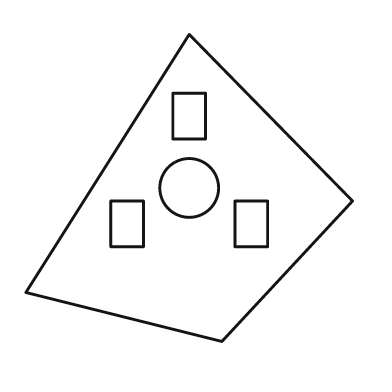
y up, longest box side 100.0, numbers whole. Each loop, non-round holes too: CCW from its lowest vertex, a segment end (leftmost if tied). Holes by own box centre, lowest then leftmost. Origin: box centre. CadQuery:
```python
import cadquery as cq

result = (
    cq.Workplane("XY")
    .moveTo(10.0, -47.0)
    .lineTo(50.0, -4.0)
    .lineTo(0.0, 47.0)
    .lineTo(-50.0, -32.0)
    .close()
    .moveTo(-24.0, -18.0)
    .lineTo(-14.0, -18.0)
    .lineTo(-14.0, -4.0)
    .lineTo(-24.0, -4.0)
    .close()
    .moveTo(14.0, -18.0)
    .lineTo(24.0, -18.0)
    .lineTo(24.0, -4.0)
    .lineTo(14.0, -4.0)
    .close()
    .moveTo(0.0, 0.0)
    .circle(9.0)
    .moveTo(-5.0, 15.0)
    .lineTo(5.0, 15.0)
    .lineTo(5.0, 29.0)
    .lineTo(-5.0, 29.0)
    .close()
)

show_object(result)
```